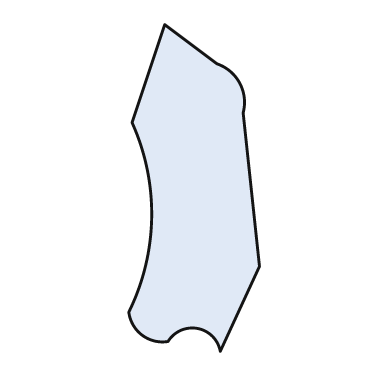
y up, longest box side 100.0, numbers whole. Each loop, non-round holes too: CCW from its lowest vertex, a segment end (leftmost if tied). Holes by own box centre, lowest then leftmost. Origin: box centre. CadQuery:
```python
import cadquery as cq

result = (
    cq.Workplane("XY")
    .moveTo(8.0, -50.0)
    .lineTo(20.0, -24.0)
    .lineTo(15.0, 23.0)
    .threePointArc((14.0, 32.0), (7.0, 38.0))
    .lineTo(-9.0, 50.0)
    .lineTo(-19.0, 20.0)
    .threePointArc((-13.0, -9.0), (-20.0, -38.0))
    .threePointArc((-16.0, -45.0), (-8.0, -47.0))
    .threePointArc((1.0, -43.0), (8.0, -50.0))
    .close()
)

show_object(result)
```